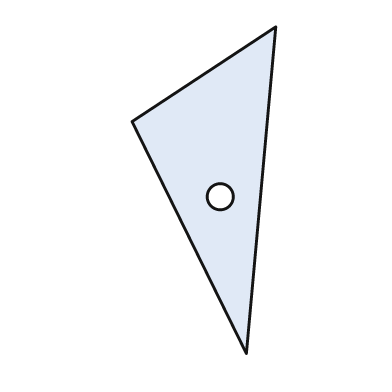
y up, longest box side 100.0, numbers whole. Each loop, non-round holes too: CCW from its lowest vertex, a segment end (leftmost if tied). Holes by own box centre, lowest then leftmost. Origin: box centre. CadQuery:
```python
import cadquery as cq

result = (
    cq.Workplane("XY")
    .moveTo(13.0, -50.0)
    .lineTo(22.0, 50.0)
    .lineTo(-22.0, 21.0)
    .close()
    .moveTo(5.0, -2.0)
    .circle(4.0)
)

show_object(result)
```